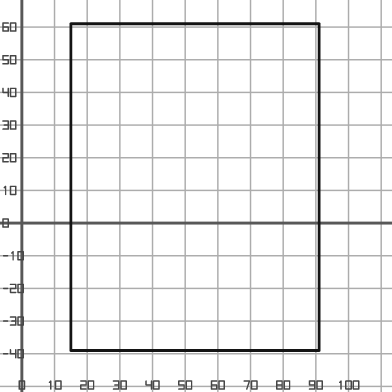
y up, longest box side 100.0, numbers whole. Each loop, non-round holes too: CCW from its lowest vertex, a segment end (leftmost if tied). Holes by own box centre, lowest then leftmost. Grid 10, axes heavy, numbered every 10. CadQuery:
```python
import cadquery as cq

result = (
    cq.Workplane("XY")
    .moveTo(15.0, -39.0)
    .lineTo(91.0, -39.0)
    .lineTo(91.0, 61.0)
    .lineTo(15.0, 61.0)
    .close()
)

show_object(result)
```